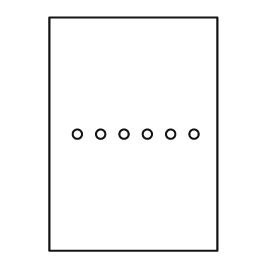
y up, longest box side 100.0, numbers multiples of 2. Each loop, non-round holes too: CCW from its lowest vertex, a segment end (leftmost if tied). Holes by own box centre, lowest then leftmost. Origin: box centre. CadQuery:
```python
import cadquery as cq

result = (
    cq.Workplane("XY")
    .moveTo(-36.0, -50.0)
    .lineTo(36.0, -50.0)
    .lineTo(36.0, 50.0)
    .lineTo(-36.0, 50.0)
    .close()
    .moveTo(-24.0, 0.0)
    .circle(2.0)
    .moveTo(-14.0, 0.0)
    .circle(2.0)
    .moveTo(-4.0, 0.0)
    .circle(2.0)
    .moveTo(6.0, 0.0)
    .circle(2.0)
    .moveTo(16.0, 0.0)
    .circle(2.0)
    .moveTo(26.0, 0.0)
    .circle(2.0)
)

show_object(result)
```